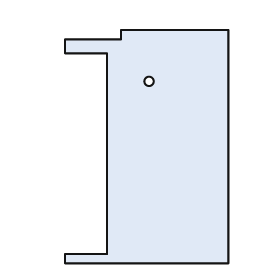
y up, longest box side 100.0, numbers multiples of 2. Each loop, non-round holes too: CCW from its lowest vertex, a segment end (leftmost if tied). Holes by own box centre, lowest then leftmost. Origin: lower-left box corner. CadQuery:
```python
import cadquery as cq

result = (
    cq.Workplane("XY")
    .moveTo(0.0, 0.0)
    .lineTo(70.0, 0.0)
    .lineTo(70.0, 100.0)
    .lineTo(24.0, 100.0)
    .lineTo(24.0, 96.0)
    .lineTo(0.0, 96.0)
    .lineTo(0.0, 90.0)
    .lineTo(18.0, 90.0)
    .lineTo(18.0, 4.0)
    .lineTo(0.0, 4.0)
    .close()
    .moveTo(36.0, 78.0)
    .circle(2.0)
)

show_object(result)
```